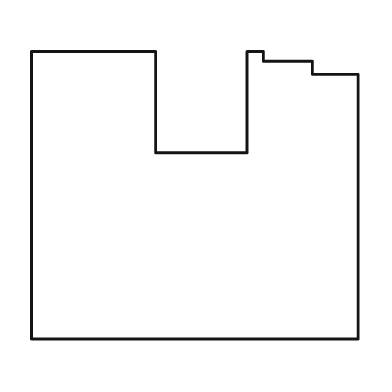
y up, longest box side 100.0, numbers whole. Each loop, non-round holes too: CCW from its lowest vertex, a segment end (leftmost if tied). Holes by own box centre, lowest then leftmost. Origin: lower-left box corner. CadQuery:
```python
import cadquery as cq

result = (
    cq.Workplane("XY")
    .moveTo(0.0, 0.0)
    .lineTo(100.0, 0.0)
    .lineTo(100.0, 81.0)
    .lineTo(86.0, 81.0)
    .lineTo(86.0, 85.0)
    .lineTo(71.0, 85.0)
    .lineTo(71.0, 88.0)
    .lineTo(66.0, 88.0)
    .lineTo(66.0, 57.0)
    .lineTo(38.0, 57.0)
    .lineTo(38.0, 88.0)
    .lineTo(0.0, 88.0)
    .close()
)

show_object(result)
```